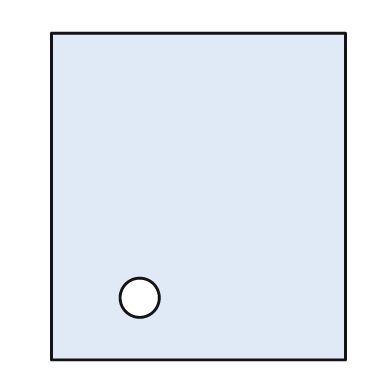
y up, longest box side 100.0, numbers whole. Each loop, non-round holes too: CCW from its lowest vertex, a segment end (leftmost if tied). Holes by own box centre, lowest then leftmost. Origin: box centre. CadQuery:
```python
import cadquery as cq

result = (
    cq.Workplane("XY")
    .moveTo(-45.0, -50.0)
    .lineTo(45.0, -50.0)
    .lineTo(45.0, 50.0)
    .lineTo(-45.0, 50.0)
    .close()
    .moveTo(-18.0, -31.0)
    .circle(6.0)
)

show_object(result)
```